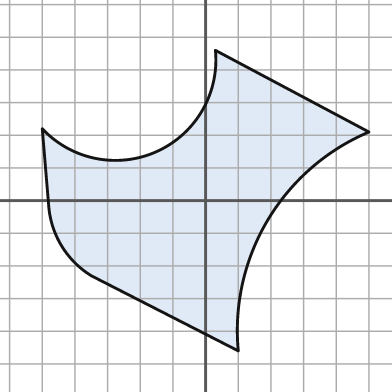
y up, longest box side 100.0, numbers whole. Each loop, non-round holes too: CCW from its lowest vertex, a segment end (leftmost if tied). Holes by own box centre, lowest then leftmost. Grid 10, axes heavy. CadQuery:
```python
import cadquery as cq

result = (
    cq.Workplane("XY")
    .moveTo(10.0, -46.0)
    .threePointArc((19.0, -6.0), (50.0, 21.0))
    .lineTo(3.0, 46.0)
    .threePointArc((-15.0, 15.0), (-50.0, 22.0))
    .lineTo(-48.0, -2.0)
    .threePointArc((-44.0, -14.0), (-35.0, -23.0))
    .close()
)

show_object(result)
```